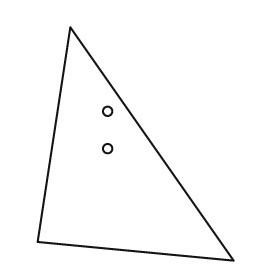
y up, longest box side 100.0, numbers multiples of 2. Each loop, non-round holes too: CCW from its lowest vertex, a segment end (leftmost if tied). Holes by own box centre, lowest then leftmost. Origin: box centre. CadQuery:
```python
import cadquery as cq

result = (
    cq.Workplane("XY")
    .moveTo(42.0, -50.0)
    .lineTo(-28.0, 50.0)
    .lineTo(-42.0, -42.0)
    .close()
    .moveTo(-12.0, -2.0)
    .circle(2.0)
    .moveTo(-12.0, 14.0)
    .circle(2.0)
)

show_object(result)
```